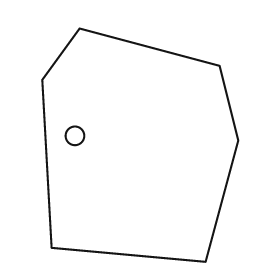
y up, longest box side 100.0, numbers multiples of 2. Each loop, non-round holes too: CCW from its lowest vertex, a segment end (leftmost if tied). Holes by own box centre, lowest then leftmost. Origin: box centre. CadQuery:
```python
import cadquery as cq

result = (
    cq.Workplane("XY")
    .moveTo(28.0, -50.0)
    .lineTo(42.0, 2.0)
    .lineTo(34.0, 34.0)
    .lineTo(-26.0, 50.0)
    .lineTo(-42.0, 28.0)
    .lineTo(-38.0, -44.0)
    .close()
    .moveTo(-28.0, 4.0)
    .circle(4.0)
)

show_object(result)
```